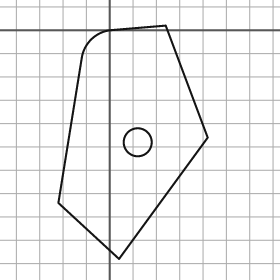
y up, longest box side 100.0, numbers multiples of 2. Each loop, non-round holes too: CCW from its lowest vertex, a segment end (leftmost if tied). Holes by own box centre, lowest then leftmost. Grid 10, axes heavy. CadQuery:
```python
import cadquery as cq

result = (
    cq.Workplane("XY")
    .moveTo(4.0, -98.0)
    .lineTo(42.0, -46.0)
    .lineTo(24.0, 2.0)
    .lineTo(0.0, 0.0)
    .threePointArc((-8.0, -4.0), (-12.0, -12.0))
    .lineTo(-22.0, -74.0)
    .close()
    .moveTo(12.0, -48.0)
    .circle(6.0)
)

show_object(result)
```